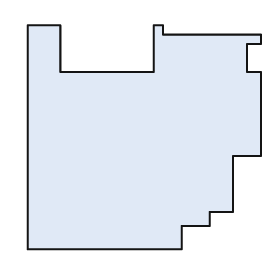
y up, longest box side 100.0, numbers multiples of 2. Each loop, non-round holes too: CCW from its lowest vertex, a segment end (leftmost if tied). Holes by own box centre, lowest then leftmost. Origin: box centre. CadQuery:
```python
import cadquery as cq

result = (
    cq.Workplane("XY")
    .moveTo(-50.0, -48.0)
    .lineTo(16.0, -48.0)
    .lineTo(16.0, -38.0)
    .lineTo(28.0, -38.0)
    .lineTo(28.0, -32.0)
    .lineTo(38.0, -32.0)
    .lineTo(38.0, -8.0)
    .lineTo(50.0, -8.0)
    .lineTo(50.0, 28.0)
    .lineTo(44.0, 28.0)
    .lineTo(44.0, 40.0)
    .lineTo(50.0, 40.0)
    .lineTo(50.0, 44.0)
    .lineTo(8.0, 44.0)
    .lineTo(8.0, 48.0)
    .lineTo(4.0, 48.0)
    .lineTo(4.0, 28.0)
    .lineTo(-36.0, 28.0)
    .lineTo(-36.0, 48.0)
    .lineTo(-50.0, 48.0)
    .close()
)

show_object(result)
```